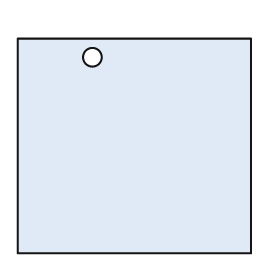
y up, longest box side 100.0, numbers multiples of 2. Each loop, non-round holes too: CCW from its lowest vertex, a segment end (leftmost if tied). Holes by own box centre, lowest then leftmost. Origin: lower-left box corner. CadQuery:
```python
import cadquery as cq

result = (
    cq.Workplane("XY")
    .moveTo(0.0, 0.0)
    .lineTo(100.0, 0.0)
    .lineTo(100.0, 92.0)
    .lineTo(0.0, 92.0)
    .close()
    .moveTo(32.0, 84.0)
    .circle(4.0)
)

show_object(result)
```